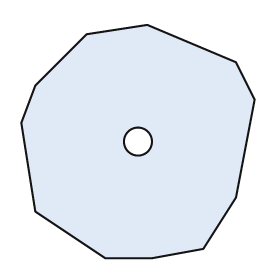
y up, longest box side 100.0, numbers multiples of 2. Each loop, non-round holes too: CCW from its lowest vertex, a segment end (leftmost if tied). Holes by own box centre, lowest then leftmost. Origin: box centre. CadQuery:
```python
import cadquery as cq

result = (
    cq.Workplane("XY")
    .moveTo(-14.0, -50.0)
    .lineTo(6.0, -50.0)
    .lineTo(28.0, -46.0)
    .lineTo(42.0, -24.0)
    .lineTo(50.0, 18.0)
    .lineTo(42.0, 34.0)
    .lineTo(4.0, 50.0)
    .lineTo(-22.0, 46.0)
    .lineTo(-44.0, 24.0)
    .lineTo(-50.0, 8.0)
    .lineTo(-44.0, -30.0)
    .close()
    .moveTo(0.0, 0.0)
    .circle(6.0)
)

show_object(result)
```